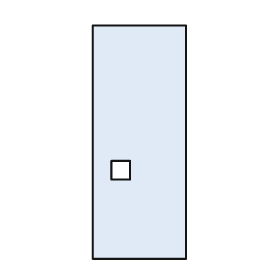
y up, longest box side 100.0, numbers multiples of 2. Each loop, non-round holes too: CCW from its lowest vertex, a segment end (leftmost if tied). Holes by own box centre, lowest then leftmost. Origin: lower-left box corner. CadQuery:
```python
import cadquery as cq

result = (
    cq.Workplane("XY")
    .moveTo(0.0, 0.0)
    .lineTo(40.0, 0.0)
    .lineTo(40.0, 100.0)
    .lineTo(0.0, 100.0)
    .close()
    .moveTo(8.0, 34.0)
    .lineTo(16.0, 34.0)
    .lineTo(16.0, 42.0)
    .lineTo(8.0, 42.0)
    .close()
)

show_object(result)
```